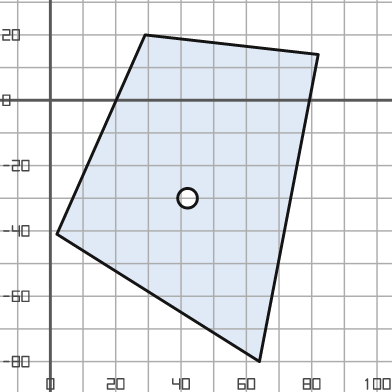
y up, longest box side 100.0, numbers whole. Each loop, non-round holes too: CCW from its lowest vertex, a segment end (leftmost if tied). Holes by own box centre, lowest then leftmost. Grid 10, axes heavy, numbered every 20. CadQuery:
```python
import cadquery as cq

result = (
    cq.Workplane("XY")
    .moveTo(64.0, -80.0)
    .lineTo(82.0, 14.0)
    .lineTo(29.0, 20.0)
    .lineTo(2.0, -41.0)
    .close()
    .moveTo(42.0, -30.0)
    .circle(3.0)
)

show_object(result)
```